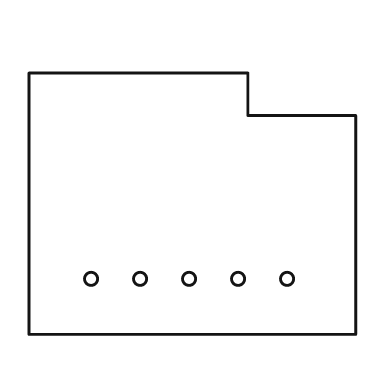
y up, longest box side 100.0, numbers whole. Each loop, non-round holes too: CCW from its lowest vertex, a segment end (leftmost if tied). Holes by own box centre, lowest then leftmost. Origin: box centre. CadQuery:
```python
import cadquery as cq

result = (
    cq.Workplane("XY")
    .moveTo(-50.0, -40.0)
    .lineTo(50.0, -40.0)
    .lineTo(50.0, 27.0)
    .lineTo(17.0, 27.0)
    .lineTo(17.0, 40.0)
    .lineTo(-50.0, 40.0)
    .close()
    .moveTo(-31.0, -23.0)
    .circle(2.0)
    .moveTo(-16.0, -23.0)
    .circle(2.0)
    .moveTo(-1.0, -23.0)
    .circle(2.0)
    .moveTo(14.0, -23.0)
    .circle(2.0)
    .moveTo(29.0, -23.0)
    .circle(2.0)
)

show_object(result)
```